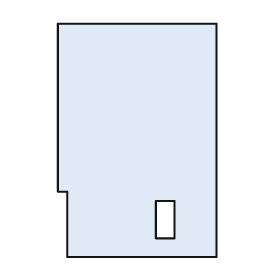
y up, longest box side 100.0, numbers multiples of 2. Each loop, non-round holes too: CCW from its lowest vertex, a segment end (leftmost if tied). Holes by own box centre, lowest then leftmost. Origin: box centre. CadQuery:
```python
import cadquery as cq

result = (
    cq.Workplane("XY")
    .moveTo(-30.0, -50.0)
    .lineTo(34.0, -50.0)
    .lineTo(34.0, 50.0)
    .lineTo(-34.0, 50.0)
    .lineTo(-34.0, -22.0)
    .lineTo(-30.0, -22.0)
    .close()
    .moveTo(8.0, -42.0)
    .lineTo(16.0, -42.0)
    .lineTo(16.0, -26.0)
    .lineTo(8.0, -26.0)
    .close()
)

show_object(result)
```